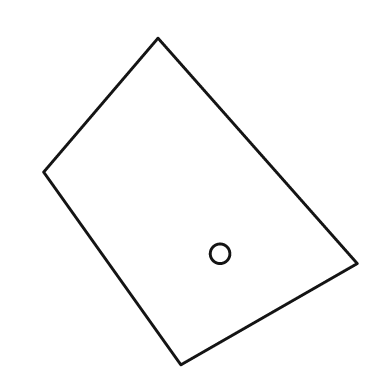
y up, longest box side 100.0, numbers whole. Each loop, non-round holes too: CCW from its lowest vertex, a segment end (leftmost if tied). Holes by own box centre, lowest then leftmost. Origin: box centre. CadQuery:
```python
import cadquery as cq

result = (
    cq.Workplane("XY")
    .moveTo(-6.0, -50.0)
    .lineTo(48.0, -19.0)
    .lineTo(-13.0, 50.0)
    .lineTo(-48.0, 9.0)
    .close()
    .moveTo(6.0, -16.0)
    .circle(3.0)
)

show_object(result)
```